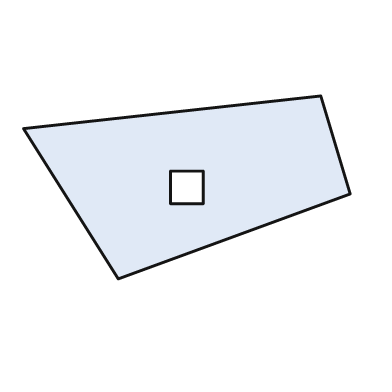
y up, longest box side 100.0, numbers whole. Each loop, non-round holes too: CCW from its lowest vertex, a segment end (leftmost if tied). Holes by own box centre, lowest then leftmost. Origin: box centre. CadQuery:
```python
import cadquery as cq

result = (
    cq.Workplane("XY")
    .moveTo(-21.0, -28.0)
    .lineTo(50.0, -2.0)
    .lineTo(41.0, 28.0)
    .lineTo(-50.0, 18.0)
    .close()
    .moveTo(-5.0, -5.0)
    .lineTo(5.0, -5.0)
    .lineTo(5.0, 5.0)
    .lineTo(-5.0, 5.0)
    .close()
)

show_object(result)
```